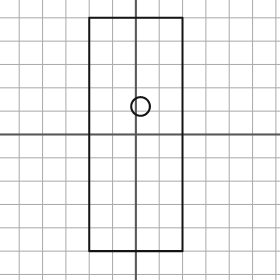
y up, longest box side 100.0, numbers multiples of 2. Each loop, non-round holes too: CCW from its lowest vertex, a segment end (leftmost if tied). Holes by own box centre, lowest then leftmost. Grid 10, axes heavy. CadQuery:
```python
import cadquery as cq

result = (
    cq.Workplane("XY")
    .moveTo(-20.0, -50.0)
    .lineTo(20.0, -50.0)
    .lineTo(20.0, 50.0)
    .lineTo(-20.0, 50.0)
    .close()
    .moveTo(2.0, 12.0)
    .circle(4.0)
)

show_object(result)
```